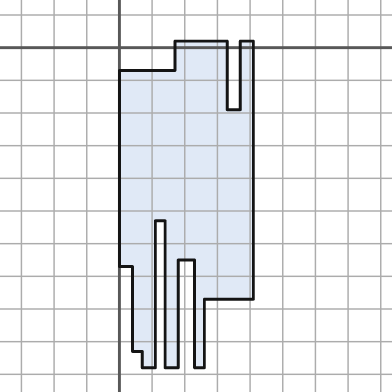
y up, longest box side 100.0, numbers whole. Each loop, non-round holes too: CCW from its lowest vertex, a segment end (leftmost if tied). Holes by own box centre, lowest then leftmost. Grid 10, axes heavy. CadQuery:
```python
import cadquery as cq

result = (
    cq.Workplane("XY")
    .moveTo(7.0, -98.0)
    .lineTo(11.0, -98.0)
    .lineTo(11.0, -53.0)
    .lineTo(14.0, -53.0)
    .lineTo(14.0, -98.0)
    .lineTo(18.0, -98.0)
    .lineTo(18.0, -65.0)
    .lineTo(23.0, -65.0)
    .lineTo(23.0, -98.0)
    .lineTo(26.0, -98.0)
    .lineTo(26.0, -77.0)
    .lineTo(41.0, -77.0)
    .lineTo(41.0, 2.0)
    .lineTo(37.0, 2.0)
    .lineTo(37.0, -19.0)
    .lineTo(33.0, -19.0)
    .lineTo(33.0, 2.0)
    .lineTo(17.0, 2.0)
    .lineTo(17.0, -7.0)
    .lineTo(0.0, -7.0)
    .lineTo(0.0, -67.0)
    .lineTo(4.0, -67.0)
    .lineTo(4.0, -93.0)
    .lineTo(7.0, -93.0)
    .close()
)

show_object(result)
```